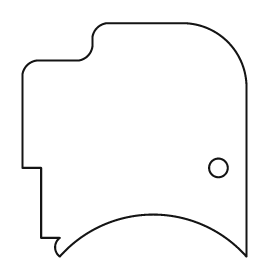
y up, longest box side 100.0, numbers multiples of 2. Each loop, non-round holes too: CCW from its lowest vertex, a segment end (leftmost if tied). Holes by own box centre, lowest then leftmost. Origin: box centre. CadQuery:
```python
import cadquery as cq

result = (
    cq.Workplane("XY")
    .moveTo(-32.0, -50.0)
    .threePointArc((8.0, -32.0), (48.0, -50.0))
    .lineTo(48.0, 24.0)
    .threePointArc((40.0, 42.0), (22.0, 50.0))
    .lineTo(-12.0, 50.0)
    .threePointArc((-16.0, 48.0), (-18.0, 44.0))
    .lineTo(-18.0, 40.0)
    .threePointArc((-20.0, 36.0), (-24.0, 34.0))
    .lineTo(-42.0, 34.0)
    .threePointArc((-46.0, 32.0), (-48.0, 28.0))
    .lineTo(-48.0, -12.0)
    .lineTo(-40.0, -12.0)
    .lineTo(-40.0, -42.0)
    .lineTo(-32.0, -42.0)
    .threePointArc((-34.0, -46.0), (-32.0, -50.0))
    .close()
    .moveTo(36.0, -12.0)
    .circle(4.0)
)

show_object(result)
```